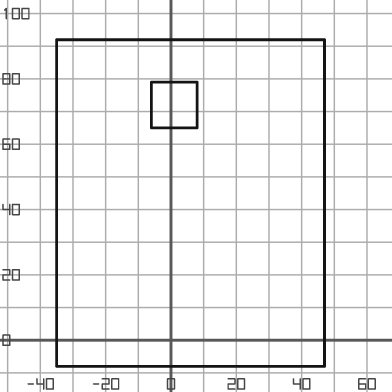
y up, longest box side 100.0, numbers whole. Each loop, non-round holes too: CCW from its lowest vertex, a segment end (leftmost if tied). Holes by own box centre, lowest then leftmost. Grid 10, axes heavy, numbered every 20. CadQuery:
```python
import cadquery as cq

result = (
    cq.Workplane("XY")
    .moveTo(-35.0, -8.0)
    .lineTo(47.0, -8.0)
    .lineTo(47.0, 92.0)
    .lineTo(-35.0, 92.0)
    .close()
    .moveTo(-6.0, 65.0)
    .lineTo(8.0, 65.0)
    .lineTo(8.0, 79.0)
    .lineTo(-6.0, 79.0)
    .close()
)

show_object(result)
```